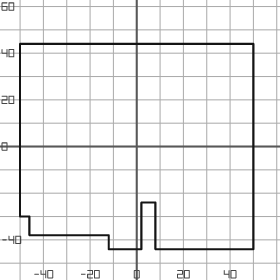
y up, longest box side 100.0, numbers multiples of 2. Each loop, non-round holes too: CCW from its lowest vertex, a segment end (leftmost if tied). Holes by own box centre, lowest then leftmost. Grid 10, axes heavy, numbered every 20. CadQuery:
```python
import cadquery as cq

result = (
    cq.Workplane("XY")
    .moveTo(-12.0, -44.0)
    .lineTo(2.0, -44.0)
    .lineTo(2.0, -24.0)
    .lineTo(8.0, -24.0)
    .lineTo(8.0, -44.0)
    .lineTo(50.0, -44.0)
    .lineTo(50.0, 44.0)
    .lineTo(-50.0, 44.0)
    .lineTo(-50.0, -30.0)
    .lineTo(-46.0, -30.0)
    .lineTo(-46.0, -38.0)
    .lineTo(-12.0, -38.0)
    .close()
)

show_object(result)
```